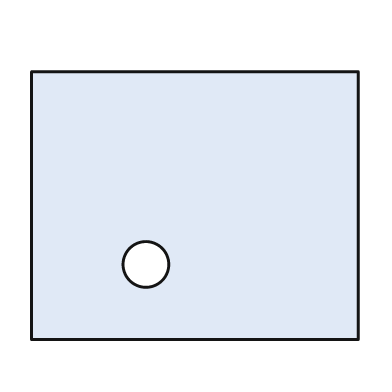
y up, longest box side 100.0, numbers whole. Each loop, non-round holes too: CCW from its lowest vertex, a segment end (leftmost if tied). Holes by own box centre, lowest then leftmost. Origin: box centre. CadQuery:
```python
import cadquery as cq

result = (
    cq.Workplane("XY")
    .moveTo(-50.0, -41.0)
    .lineTo(50.0, -41.0)
    .lineTo(50.0, 41.0)
    .lineTo(-50.0, 41.0)
    .close()
    .moveTo(-15.0, -18.0)
    .circle(7.0)
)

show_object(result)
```